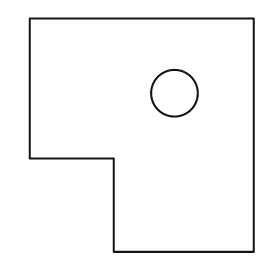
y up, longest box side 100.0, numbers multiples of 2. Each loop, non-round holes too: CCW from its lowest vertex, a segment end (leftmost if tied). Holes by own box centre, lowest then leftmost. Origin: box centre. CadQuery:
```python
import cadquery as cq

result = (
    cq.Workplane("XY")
    .moveTo(-12.0, -50.0)
    .lineTo(48.0, -50.0)
    .lineTo(48.0, 50.0)
    .lineTo(-48.0, 50.0)
    .lineTo(-48.0, -10.0)
    .lineTo(-12.0, -10.0)
    .close()
    .moveTo(14.0, 18.0)
    .circle(10.0)
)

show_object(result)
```